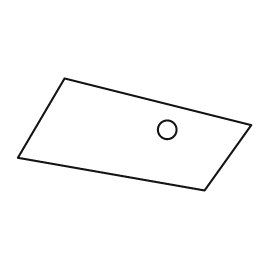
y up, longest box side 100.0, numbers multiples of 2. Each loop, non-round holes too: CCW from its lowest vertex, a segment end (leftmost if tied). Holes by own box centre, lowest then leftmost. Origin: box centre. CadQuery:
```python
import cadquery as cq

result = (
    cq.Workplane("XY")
    .moveTo(30.0, -24.0)
    .lineTo(50.0, 4.0)
    .lineTo(-30.0, 24.0)
    .lineTo(-50.0, -10.0)
    .close()
    .moveTo(14.0, 2.0)
    .circle(4.0)
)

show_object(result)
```